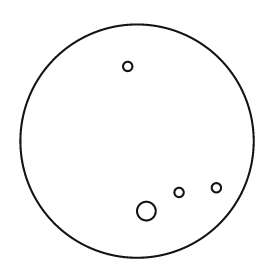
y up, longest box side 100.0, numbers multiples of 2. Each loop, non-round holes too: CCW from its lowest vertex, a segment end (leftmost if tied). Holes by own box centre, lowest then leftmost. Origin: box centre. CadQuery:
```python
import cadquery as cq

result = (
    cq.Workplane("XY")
    .moveTo(0.0, 0.0)
    .circle(50.0)
    .moveTo(4.0, -30.0)
    .circle(4.0)
    .moveTo(18.0, -22.0)
    .circle(2.0)
    .moveTo(34.0, -20.0)
    .circle(2.0)
    .moveTo(-4.0, 32.0)
    .circle(2.0)
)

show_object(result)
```